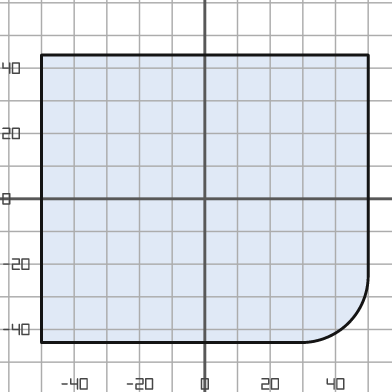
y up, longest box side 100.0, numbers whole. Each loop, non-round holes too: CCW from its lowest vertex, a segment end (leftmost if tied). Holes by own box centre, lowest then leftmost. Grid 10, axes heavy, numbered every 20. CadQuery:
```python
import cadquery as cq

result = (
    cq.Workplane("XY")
    .moveTo(-50.0, -44.0)
    .lineTo(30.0, -44.0)
    .threePointArc((44.0, -38.0), (50.0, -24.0))
    .lineTo(50.0, 44.0)
    .lineTo(-50.0, 44.0)
    .close()
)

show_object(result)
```